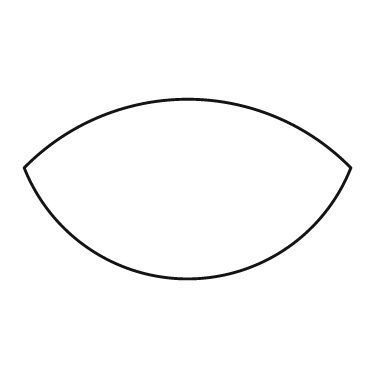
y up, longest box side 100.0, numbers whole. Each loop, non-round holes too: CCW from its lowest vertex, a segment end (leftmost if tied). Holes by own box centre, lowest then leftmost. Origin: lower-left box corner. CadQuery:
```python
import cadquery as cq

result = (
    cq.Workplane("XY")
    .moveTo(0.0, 34.0)
    .threePointArc((50.0, 0.0), (100.0, 34.0))
    .threePointArc((50.0, 55.0), (0.0, 34.0))
    .close()
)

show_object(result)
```